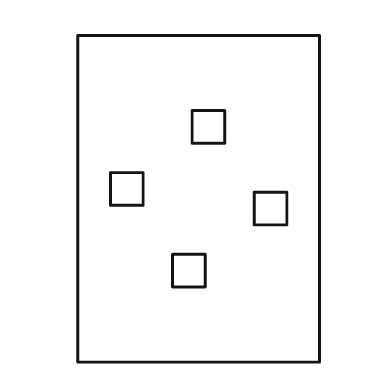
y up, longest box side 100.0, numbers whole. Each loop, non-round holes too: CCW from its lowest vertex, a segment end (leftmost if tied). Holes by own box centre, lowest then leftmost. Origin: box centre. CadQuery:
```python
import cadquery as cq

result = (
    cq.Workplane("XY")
    .moveTo(-37.0, -50.0)
    .lineTo(37.0, -50.0)
    .lineTo(37.0, 50.0)
    .lineTo(-37.0, 50.0)
    .close()
    .moveTo(-8.0, -27.0)
    .lineTo(2.0, -27.0)
    .lineTo(2.0, -17.0)
    .lineTo(-8.0, -17.0)
    .close()
    .moveTo(17.0, -8.0)
    .lineTo(27.0, -8.0)
    .lineTo(27.0, 2.0)
    .lineTo(17.0, 2.0)
    .close()
    .moveTo(-27.0, -2.0)
    .lineTo(-17.0, -2.0)
    .lineTo(-17.0, 8.0)
    .lineTo(-27.0, 8.0)
    .close()
    .moveTo(-2.0, 17.0)
    .lineTo(8.0, 17.0)
    .lineTo(8.0, 27.0)
    .lineTo(-2.0, 27.0)
    .close()
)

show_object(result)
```